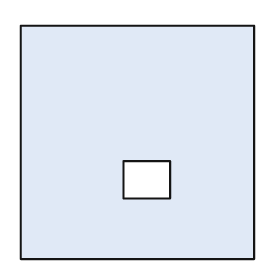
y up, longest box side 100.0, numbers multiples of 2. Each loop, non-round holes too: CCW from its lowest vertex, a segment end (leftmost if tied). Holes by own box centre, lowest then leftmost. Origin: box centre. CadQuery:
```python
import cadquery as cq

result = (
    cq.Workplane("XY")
    .moveTo(-50.0, -50.0)
    .lineTo(50.0, -50.0)
    .lineTo(50.0, 50.0)
    .lineTo(-50.0, 50.0)
    .close()
    .moveTo(-6.0, -24.0)
    .lineTo(14.0, -24.0)
    .lineTo(14.0, -8.0)
    .lineTo(-6.0, -8.0)
    .close()
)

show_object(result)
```